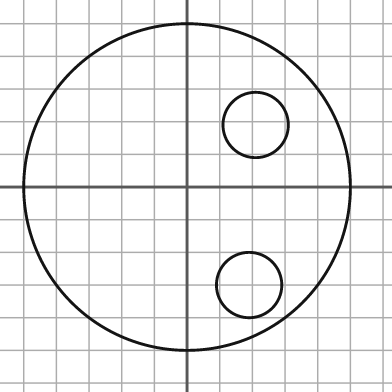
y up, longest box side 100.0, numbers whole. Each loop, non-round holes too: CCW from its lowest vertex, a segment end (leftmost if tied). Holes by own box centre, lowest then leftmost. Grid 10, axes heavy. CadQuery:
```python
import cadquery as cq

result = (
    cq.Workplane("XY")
    .moveTo(0.0, 0.0)
    .circle(50.0)
    .moveTo(19.0, -30.0)
    .circle(10.0)
    .moveTo(21.0, 19.0)
    .circle(10.0)
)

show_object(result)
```